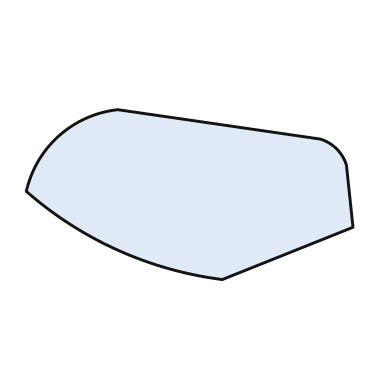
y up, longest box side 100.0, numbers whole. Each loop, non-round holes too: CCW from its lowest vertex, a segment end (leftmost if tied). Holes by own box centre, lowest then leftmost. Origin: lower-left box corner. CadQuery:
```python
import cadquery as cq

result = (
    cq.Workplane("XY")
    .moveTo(60.0, 0.0)
    .lineTo(100.0, 16.0)
    .lineTo(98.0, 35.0)
    .threePointArc((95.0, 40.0), (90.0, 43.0))
    .lineTo(28.0, 52.0)
    .threePointArc((10.0, 44.0), (0.0, 27.0))
    .threePointArc((28.0, 9.0), (60.0, 0.0))
    .close()
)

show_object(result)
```